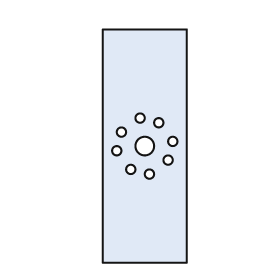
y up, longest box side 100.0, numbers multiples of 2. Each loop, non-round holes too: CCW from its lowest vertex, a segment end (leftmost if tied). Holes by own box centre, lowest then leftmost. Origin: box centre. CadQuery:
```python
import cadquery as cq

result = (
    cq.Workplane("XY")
    .moveTo(-18.0, -50.0)
    .lineTo(18.0, -50.0)
    .lineTo(18.0, 50.0)
    .lineTo(-18.0, 50.0)
    .close()
    .moveTo(2.0, -12.0)
    .circle(2.0)
    .moveTo(-6.0, -10.0)
    .circle(2.0)
    .moveTo(10.0, -6.0)
    .circle(2.0)
    .moveTo(-12.0, -2.0)
    .circle(2.0)
    .moveTo(0.0, 0.0)
    .circle(4.0)
    .moveTo(12.0, 2.0)
    .circle(2.0)
    .moveTo(-10.0, 6.0)
    .circle(2.0)
    .moveTo(6.0, 10.0)
    .circle(2.0)
    .moveTo(-2.0, 12.0)
    .circle(2.0)
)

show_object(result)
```